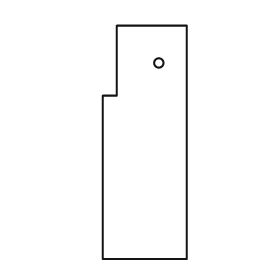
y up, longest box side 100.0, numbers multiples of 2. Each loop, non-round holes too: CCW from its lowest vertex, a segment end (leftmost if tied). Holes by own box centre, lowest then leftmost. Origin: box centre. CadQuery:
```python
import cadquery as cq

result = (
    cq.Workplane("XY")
    .moveTo(-18.0, -50.0)
    .lineTo(18.0, -50.0)
    .lineTo(18.0, 50.0)
    .lineTo(-12.0, 50.0)
    .lineTo(-12.0, 20.0)
    .lineTo(-18.0, 20.0)
    .close()
    .moveTo(6.0, 34.0)
    .circle(2.0)
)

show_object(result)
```